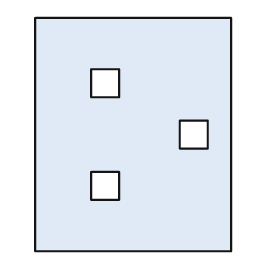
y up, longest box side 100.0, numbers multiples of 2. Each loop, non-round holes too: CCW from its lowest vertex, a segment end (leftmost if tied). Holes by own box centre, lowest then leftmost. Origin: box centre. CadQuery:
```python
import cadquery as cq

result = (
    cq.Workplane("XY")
    .moveTo(-42.0, -50.0)
    .lineTo(42.0, -50.0)
    .lineTo(42.0, 50.0)
    .lineTo(-42.0, 50.0)
    .close()
    .moveTo(-18.0, -28.0)
    .lineTo(-6.0, -28.0)
    .lineTo(-6.0, -16.0)
    .lineTo(-18.0, -16.0)
    .close()
    .moveTo(20.0, -6.0)
    .lineTo(32.0, -6.0)
    .lineTo(32.0, 6.0)
    .lineTo(20.0, 6.0)
    .close()
    .moveTo(-18.0, 16.0)
    .lineTo(-6.0, 16.0)
    .lineTo(-6.0, 28.0)
    .lineTo(-18.0, 28.0)
    .close()
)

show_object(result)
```